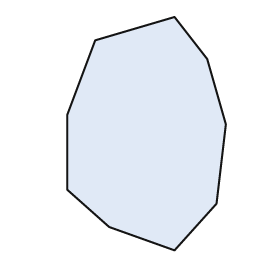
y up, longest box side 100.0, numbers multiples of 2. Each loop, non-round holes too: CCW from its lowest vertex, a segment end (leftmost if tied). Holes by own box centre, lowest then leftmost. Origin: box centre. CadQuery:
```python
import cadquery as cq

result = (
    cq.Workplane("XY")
    .moveTo(12.0, -50.0)
    .lineTo(30.0, -30.0)
    .lineTo(34.0, 4.0)
    .lineTo(26.0, 32.0)
    .lineTo(12.0, 50.0)
    .lineTo(-22.0, 40.0)
    .lineTo(-34.0, 8.0)
    .lineTo(-34.0, -24.0)
    .lineTo(-16.0, -40.0)
    .close()
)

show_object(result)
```